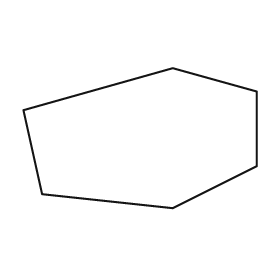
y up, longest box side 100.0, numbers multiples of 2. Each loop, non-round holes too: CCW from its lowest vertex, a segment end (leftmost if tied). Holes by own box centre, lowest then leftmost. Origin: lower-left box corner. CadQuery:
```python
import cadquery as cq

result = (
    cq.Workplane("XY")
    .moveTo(64.0, 0.0)
    .lineTo(100.0, 18.0)
    .lineTo(100.0, 50.0)
    .lineTo(64.0, 60.0)
    .lineTo(0.0, 42.0)
    .lineTo(8.0, 6.0)
    .close()
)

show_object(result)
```